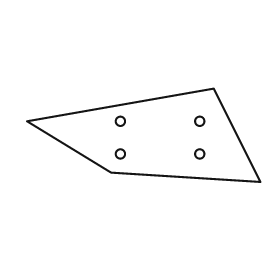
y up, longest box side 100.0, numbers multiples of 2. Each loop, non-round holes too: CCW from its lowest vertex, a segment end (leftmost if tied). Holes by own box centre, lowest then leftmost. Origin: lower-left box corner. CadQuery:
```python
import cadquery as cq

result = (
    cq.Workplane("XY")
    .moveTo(100.0, 0.0)
    .lineTo(80.0, 40.0)
    .lineTo(0.0, 26.0)
    .lineTo(36.0, 4.0)
    .close()
    .moveTo(40.0, 12.0)
    .circle(2.0)
    .moveTo(74.0, 12.0)
    .circle(2.0)
    .moveTo(40.0, 26.0)
    .circle(2.0)
    .moveTo(74.0, 26.0)
    .circle(2.0)
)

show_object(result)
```